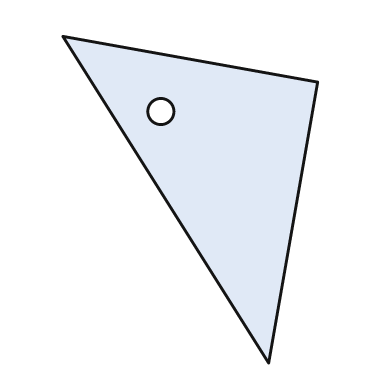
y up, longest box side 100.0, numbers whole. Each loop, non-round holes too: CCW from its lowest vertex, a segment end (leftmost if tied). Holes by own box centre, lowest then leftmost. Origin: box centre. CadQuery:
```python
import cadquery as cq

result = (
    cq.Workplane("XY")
    .moveTo(24.0, -50.0)
    .lineTo(39.0, 36.0)
    .lineTo(-39.0, 50.0)
    .close()
    .moveTo(-9.0, 27.0)
    .circle(4.0)
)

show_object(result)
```